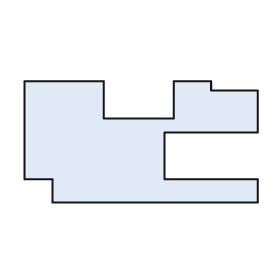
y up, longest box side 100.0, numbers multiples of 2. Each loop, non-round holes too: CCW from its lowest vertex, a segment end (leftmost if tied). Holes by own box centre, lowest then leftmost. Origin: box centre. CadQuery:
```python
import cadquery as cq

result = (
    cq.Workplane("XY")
    .moveTo(-38.0, -26.0)
    .lineTo(50.0, -26.0)
    .lineTo(50.0, -16.0)
    .lineTo(10.0, -16.0)
    .lineTo(10.0, 4.0)
    .lineTo(50.0, 4.0)
    .lineTo(50.0, 22.0)
    .lineTo(30.0, 22.0)
    .lineTo(30.0, 26.0)
    .lineTo(14.0, 26.0)
    .lineTo(14.0, 10.0)
    .lineTo(-16.0, 10.0)
    .lineTo(-16.0, 26.0)
    .lineTo(-50.0, 26.0)
    .lineTo(-50.0, -16.0)
    .lineTo(-38.0, -16.0)
    .close()
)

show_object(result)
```